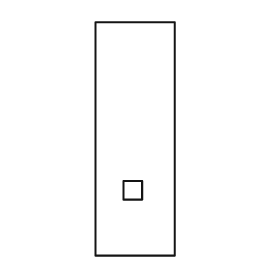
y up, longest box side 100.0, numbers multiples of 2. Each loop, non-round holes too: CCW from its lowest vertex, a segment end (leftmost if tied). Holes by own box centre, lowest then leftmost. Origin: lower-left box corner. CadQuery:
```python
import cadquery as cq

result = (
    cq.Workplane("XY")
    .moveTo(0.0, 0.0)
    .lineTo(34.0, 0.0)
    .lineTo(34.0, 100.0)
    .lineTo(0.0, 100.0)
    .close()
    .moveTo(12.0, 24.0)
    .lineTo(20.0, 24.0)
    .lineTo(20.0, 32.0)
    .lineTo(12.0, 32.0)
    .close()
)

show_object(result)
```